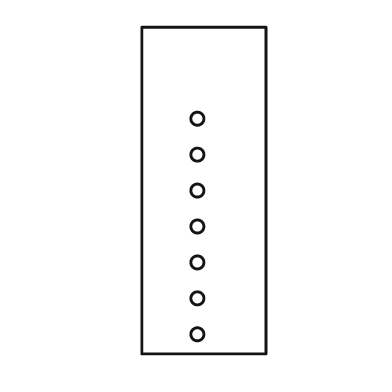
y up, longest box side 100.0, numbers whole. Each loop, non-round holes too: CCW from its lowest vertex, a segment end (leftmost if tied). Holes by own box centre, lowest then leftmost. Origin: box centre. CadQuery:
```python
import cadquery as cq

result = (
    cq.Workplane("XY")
    .moveTo(-19.0, -50.0)
    .lineTo(19.0, -50.0)
    .lineTo(19.0, 50.0)
    .lineTo(-19.0, 50.0)
    .close()
    .moveTo(-2.0, -44.0)
    .circle(2.0)
    .moveTo(-2.0, -33.0)
    .circle(2.0)
    .moveTo(-2.0, -22.0)
    .circle(2.0)
    .moveTo(-2.0, -11.0)
    .circle(2.0)
    .moveTo(-2.0, 0.0)
    .circle(2.0)
    .moveTo(-2.0, 11.0)
    .circle(2.0)
    .moveTo(-2.0, 22.0)
    .circle(2.0)
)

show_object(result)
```